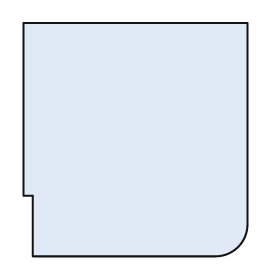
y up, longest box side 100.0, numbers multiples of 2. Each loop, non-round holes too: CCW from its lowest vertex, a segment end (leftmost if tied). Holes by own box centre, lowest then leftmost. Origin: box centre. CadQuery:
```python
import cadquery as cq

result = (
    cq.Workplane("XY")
    .moveTo(-44.0, -50.0)
    .lineTo(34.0, -50.0)
    .threePointArc((44.0, -46.0), (48.0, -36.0))
    .lineTo(48.0, 50.0)
    .lineTo(-48.0, 50.0)
    .lineTo(-48.0, -24.0)
    .lineTo(-44.0, -24.0)
    .close()
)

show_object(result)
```